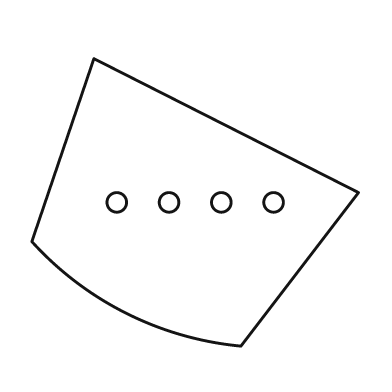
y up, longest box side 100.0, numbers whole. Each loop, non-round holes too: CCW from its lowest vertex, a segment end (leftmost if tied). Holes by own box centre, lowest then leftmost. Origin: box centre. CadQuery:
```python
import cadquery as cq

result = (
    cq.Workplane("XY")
    .moveTo(14.0, -44.0)
    .lineTo(50.0, 3.0)
    .lineTo(-31.0, 44.0)
    .lineTo(-50.0, -12.0)
    .threePointArc((-21.0, -34.0), (14.0, -44.0))
    .close()
    .moveTo(-24.0, 0.0)
    .circle(3.0)
    .moveTo(-8.0, 0.0)
    .circle(3.0)
    .moveTo(8.0, 0.0)
    .circle(3.0)
    .moveTo(24.0, 0.0)
    .circle(3.0)
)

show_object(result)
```